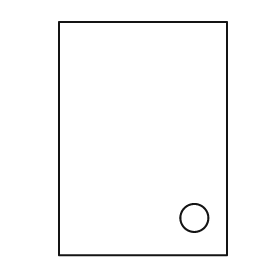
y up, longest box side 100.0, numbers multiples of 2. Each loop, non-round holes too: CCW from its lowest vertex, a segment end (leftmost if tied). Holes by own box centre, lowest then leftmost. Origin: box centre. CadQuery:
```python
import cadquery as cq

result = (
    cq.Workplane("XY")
    .moveTo(-36.0, -50.0)
    .lineTo(36.0, -50.0)
    .lineTo(36.0, 50.0)
    .lineTo(-36.0, 50.0)
    .close()
    .moveTo(22.0, -34.0)
    .circle(6.0)
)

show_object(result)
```